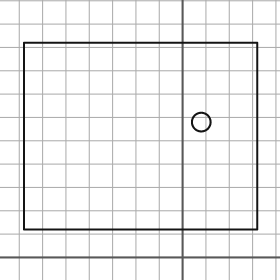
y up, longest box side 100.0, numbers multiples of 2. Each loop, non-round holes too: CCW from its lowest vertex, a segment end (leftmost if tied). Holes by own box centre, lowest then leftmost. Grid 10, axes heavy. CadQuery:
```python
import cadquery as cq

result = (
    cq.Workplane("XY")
    .moveTo(-68.0, 12.0)
    .lineTo(32.0, 12.0)
    .lineTo(32.0, 92.0)
    .lineTo(-68.0, 92.0)
    .close()
    .moveTo(8.0, 58.0)
    .circle(4.0)
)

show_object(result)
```